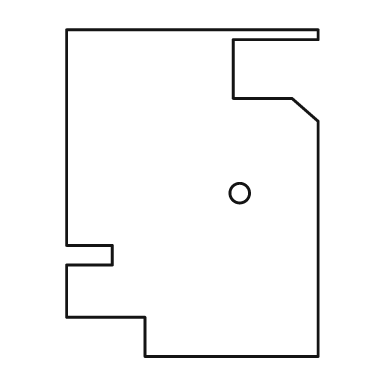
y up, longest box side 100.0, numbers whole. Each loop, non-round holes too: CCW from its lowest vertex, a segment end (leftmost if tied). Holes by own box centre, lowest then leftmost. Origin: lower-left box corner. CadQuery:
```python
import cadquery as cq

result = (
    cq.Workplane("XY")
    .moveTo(24.0, 0.0)
    .lineTo(77.0, 0.0)
    .lineTo(77.0, 72.0)
    .lineTo(69.0, 79.0)
    .lineTo(51.0, 79.0)
    .lineTo(51.0, 97.0)
    .lineTo(77.0, 97.0)
    .lineTo(77.0, 100.0)
    .lineTo(0.0, 100.0)
    .lineTo(0.0, 34.0)
    .lineTo(14.0, 34.0)
    .lineTo(14.0, 28.0)
    .lineTo(0.0, 28.0)
    .lineTo(0.0, 12.0)
    .lineTo(24.0, 12.0)
    .close()
    .moveTo(53.0, 50.0)
    .circle(3.0)
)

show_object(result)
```